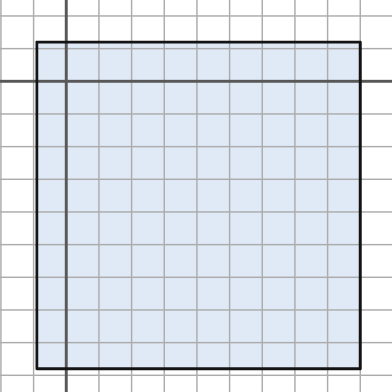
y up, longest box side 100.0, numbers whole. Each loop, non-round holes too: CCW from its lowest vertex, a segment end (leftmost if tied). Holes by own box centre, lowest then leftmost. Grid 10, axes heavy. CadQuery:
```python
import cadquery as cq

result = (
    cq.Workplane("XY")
    .moveTo(-9.0, -88.0)
    .lineTo(90.0, -88.0)
    .lineTo(90.0, 12.0)
    .lineTo(-9.0, 12.0)
    .close()
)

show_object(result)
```